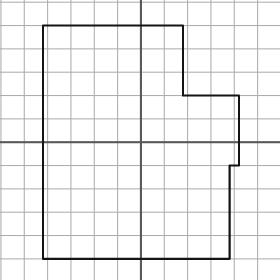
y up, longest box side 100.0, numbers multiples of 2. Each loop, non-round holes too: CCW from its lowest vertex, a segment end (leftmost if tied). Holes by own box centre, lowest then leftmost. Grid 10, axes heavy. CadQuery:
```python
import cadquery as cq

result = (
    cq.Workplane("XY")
    .moveTo(-42.0, -50.0)
    .lineTo(38.0, -50.0)
    .lineTo(38.0, -10.0)
    .lineTo(42.0, -10.0)
    .lineTo(42.0, 20.0)
    .lineTo(18.0, 20.0)
    .lineTo(18.0, 50.0)
    .lineTo(-42.0, 50.0)
    .close()
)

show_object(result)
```